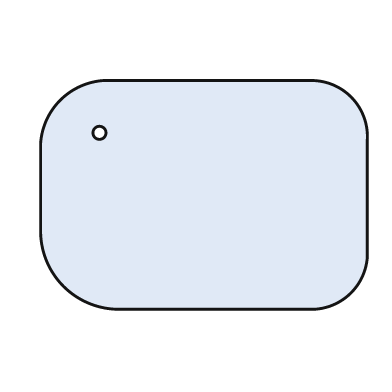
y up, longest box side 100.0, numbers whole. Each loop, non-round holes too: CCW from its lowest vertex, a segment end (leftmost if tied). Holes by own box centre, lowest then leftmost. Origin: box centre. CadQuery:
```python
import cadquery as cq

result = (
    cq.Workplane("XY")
    .moveTo(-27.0, -35.0)
    .lineTo(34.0, -35.0)
    .threePointArc((45.0, -30.0), (50.0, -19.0))
    .lineTo(50.0, 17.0)
    .threePointArc((45.0, 30.0), (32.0, 35.0))
    .lineTo(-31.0, 35.0)
    .threePointArc((-44.0, 29.0), (-50.0, 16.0))
    .lineTo(-50.0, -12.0)
    .threePointArc((-43.0, -28.0), (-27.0, -35.0))
    .close()
    .moveTo(-32.0, 19.0)
    .circle(2.0)
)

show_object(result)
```